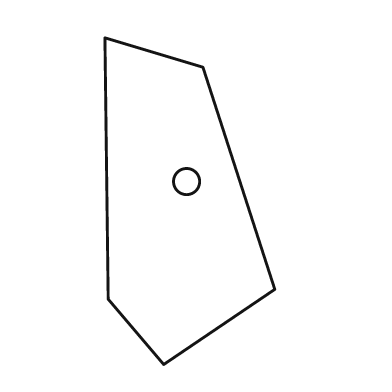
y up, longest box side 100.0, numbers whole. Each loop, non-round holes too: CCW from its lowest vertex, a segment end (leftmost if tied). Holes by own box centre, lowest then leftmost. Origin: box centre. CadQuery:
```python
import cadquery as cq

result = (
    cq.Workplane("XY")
    .moveTo(-8.0, -50.0)
    .lineTo(26.0, -27.0)
    .lineTo(4.0, 41.0)
    .lineTo(-26.0, 50.0)
    .lineTo(-25.0, -30.0)
    .close()
    .moveTo(-1.0, 6.0)
    .circle(4.0)
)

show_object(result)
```